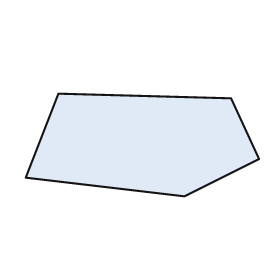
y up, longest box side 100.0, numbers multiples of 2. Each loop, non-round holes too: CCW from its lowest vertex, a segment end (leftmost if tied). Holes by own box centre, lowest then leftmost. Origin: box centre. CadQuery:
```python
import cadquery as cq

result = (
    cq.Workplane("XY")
    .moveTo(18.0, -22.0)
    .lineTo(50.0, -6.0)
    .lineTo(38.0, 20.0)
    .lineTo(-36.0, 22.0)
    .lineTo(-50.0, -14.0)
    .close()
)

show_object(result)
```